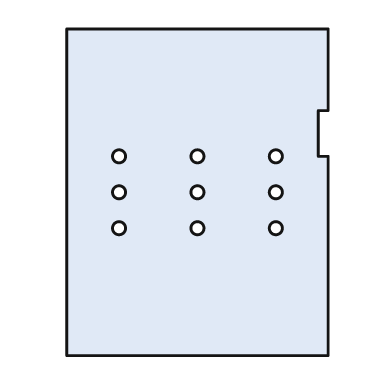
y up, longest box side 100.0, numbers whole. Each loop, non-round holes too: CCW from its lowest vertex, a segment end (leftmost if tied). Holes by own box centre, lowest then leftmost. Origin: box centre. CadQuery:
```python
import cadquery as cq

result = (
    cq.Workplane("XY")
    .moveTo(-40.0, -50.0)
    .lineTo(40.0, -50.0)
    .lineTo(40.0, 11.0)
    .lineTo(37.0, 11.0)
    .lineTo(37.0, 25.0)
    .lineTo(40.0, 25.0)
    .lineTo(40.0, 50.0)
    .lineTo(-40.0, 50.0)
    .close()
    .moveTo(-24.0, -11.0)
    .circle(2.0)
    .moveTo(0.0, -11.0)
    .circle(2.0)
    .moveTo(24.0, -11.0)
    .circle(2.0)
    .moveTo(-24.0, 0.0)
    .circle(2.0)
    .moveTo(0.0, 0.0)
    .circle(2.0)
    .moveTo(24.0, 0.0)
    .circle(2.0)
    .moveTo(-24.0, 11.0)
    .circle(2.0)
    .moveTo(0.0, 11.0)
    .circle(2.0)
    .moveTo(24.0, 11.0)
    .circle(2.0)
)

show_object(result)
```